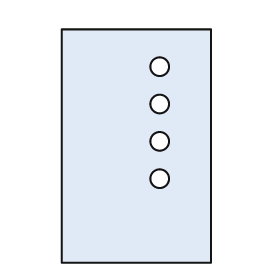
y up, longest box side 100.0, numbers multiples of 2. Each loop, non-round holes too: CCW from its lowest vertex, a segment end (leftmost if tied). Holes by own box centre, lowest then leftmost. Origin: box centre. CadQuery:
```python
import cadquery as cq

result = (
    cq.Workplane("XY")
    .moveTo(-32.0, -50.0)
    .lineTo(32.0, -50.0)
    .lineTo(32.0, 50.0)
    .lineTo(-32.0, 50.0)
    .close()
    .moveTo(10.0, -14.0)
    .circle(4.0)
    .moveTo(10.0, 2.0)
    .circle(4.0)
    .moveTo(10.0, 18.0)
    .circle(4.0)
    .moveTo(10.0, 34.0)
    .circle(4.0)
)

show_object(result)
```